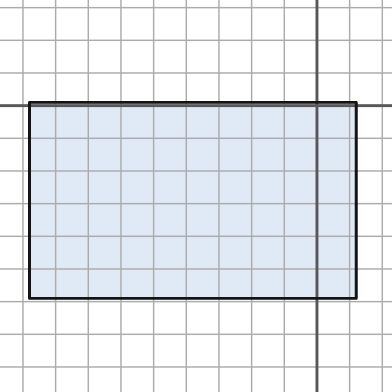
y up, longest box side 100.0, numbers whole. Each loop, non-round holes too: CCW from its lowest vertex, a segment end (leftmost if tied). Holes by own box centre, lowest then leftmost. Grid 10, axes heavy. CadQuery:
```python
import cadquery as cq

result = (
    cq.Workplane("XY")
    .moveTo(-88.0, -59.0)
    .lineTo(12.0, -59.0)
    .lineTo(12.0, 1.0)
    .lineTo(-88.0, 1.0)
    .close()
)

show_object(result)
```